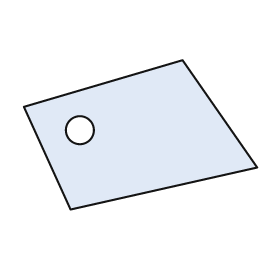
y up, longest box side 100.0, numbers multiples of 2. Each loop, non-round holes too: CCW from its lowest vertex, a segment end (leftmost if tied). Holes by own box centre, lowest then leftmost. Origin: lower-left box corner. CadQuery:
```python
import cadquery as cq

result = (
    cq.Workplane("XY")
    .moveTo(20.0, 0.0)
    .lineTo(100.0, 18.0)
    .lineTo(68.0, 64.0)
    .lineTo(0.0, 44.0)
    .close()
    .moveTo(24.0, 34.0)
    .circle(6.0)
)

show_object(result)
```